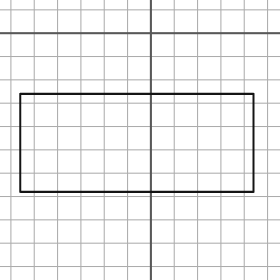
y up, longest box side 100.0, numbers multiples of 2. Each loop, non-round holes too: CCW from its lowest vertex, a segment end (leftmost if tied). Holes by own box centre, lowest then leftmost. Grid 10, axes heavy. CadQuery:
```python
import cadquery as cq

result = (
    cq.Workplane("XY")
    .moveTo(-56.0, -68.0)
    .lineTo(44.0, -68.0)
    .lineTo(44.0, -26.0)
    .lineTo(-56.0, -26.0)
    .close()
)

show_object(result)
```